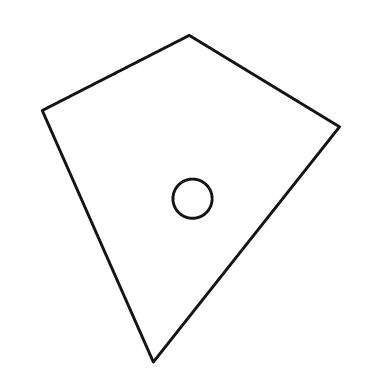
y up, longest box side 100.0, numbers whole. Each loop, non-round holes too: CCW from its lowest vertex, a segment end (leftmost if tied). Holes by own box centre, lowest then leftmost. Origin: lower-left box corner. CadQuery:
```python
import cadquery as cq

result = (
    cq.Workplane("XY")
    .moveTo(34.0, 0.0)
    .lineTo(91.0, 72.0)
    .lineTo(45.0, 100.0)
    .lineTo(0.0, 77.0)
    .close()
    .moveTo(46.0, 50.0)
    .circle(6.0)
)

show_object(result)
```